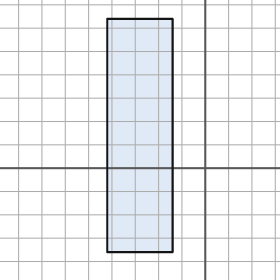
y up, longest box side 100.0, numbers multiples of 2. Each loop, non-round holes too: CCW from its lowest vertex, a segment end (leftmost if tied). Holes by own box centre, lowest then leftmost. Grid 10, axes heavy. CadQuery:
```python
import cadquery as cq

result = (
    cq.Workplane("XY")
    .moveTo(-42.0, -36.0)
    .lineTo(-14.0, -36.0)
    .lineTo(-14.0, 64.0)
    .lineTo(-42.0, 64.0)
    .close()
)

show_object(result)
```